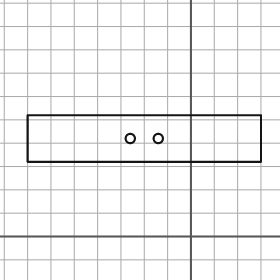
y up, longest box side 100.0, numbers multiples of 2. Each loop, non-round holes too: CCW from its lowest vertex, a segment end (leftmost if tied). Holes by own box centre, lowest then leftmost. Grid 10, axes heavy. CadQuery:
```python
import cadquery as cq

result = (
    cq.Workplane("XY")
    .moveTo(-70.0, 32.0)
    .lineTo(30.0, 32.0)
    .lineTo(30.0, 52.0)
    .lineTo(-70.0, 52.0)
    .close()
    .moveTo(-26.0, 42.0)
    .circle(2.0)
    .moveTo(-14.0, 42.0)
    .circle(2.0)
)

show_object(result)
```